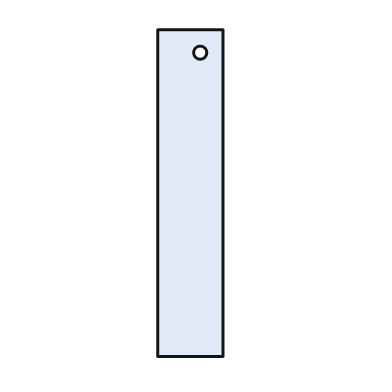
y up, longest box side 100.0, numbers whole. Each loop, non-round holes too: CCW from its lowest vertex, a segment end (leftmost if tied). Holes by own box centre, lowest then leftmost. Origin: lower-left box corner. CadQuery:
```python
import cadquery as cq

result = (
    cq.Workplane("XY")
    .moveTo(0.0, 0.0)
    .lineTo(20.0, 0.0)
    .lineTo(20.0, 100.0)
    .lineTo(0.0, 100.0)
    .close()
    .moveTo(13.0, 93.0)
    .circle(2.0)
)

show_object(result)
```